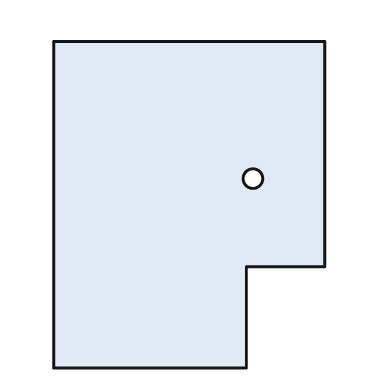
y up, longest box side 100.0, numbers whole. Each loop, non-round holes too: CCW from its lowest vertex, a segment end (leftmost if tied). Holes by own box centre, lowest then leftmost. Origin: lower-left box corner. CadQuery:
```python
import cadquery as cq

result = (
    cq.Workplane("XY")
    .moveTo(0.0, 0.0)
    .lineTo(59.0, 0.0)
    .lineTo(59.0, 31.0)
    .lineTo(83.0, 31.0)
    .lineTo(83.0, 100.0)
    .lineTo(0.0, 100.0)
    .close()
    .moveTo(61.0, 58.0)
    .circle(3.0)
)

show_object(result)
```